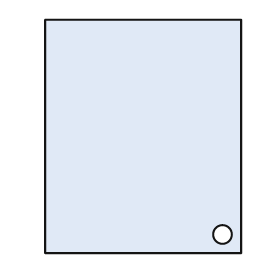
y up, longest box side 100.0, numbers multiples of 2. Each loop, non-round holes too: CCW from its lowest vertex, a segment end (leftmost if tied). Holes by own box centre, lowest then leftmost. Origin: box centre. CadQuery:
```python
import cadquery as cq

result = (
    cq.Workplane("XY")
    .moveTo(-42.0, -50.0)
    .lineTo(42.0, -50.0)
    .lineTo(42.0, 50.0)
    .lineTo(-42.0, 50.0)
    .close()
    .moveTo(34.0, -42.0)
    .circle(4.0)
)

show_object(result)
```